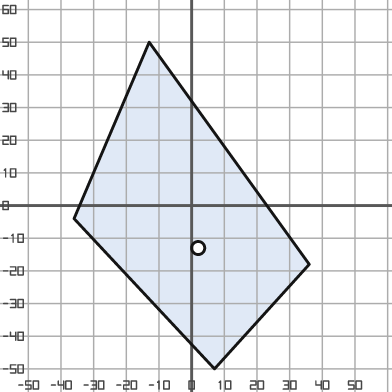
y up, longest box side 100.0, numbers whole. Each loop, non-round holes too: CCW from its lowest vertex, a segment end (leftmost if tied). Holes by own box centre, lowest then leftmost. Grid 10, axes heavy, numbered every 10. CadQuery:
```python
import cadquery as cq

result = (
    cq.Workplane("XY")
    .moveTo(7.0, -50.0)
    .lineTo(36.0, -18.0)
    .lineTo(-13.0, 50.0)
    .lineTo(-36.0, -4.0)
    .close()
    .moveTo(2.0, -13.0)
    .circle(2.0)
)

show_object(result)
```